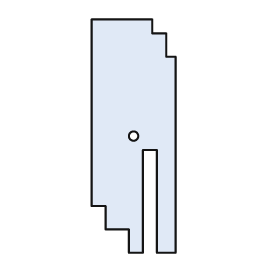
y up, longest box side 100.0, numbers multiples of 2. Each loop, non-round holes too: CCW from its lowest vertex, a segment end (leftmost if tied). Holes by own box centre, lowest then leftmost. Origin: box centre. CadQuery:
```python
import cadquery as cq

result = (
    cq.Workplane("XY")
    .moveTo(-2.0, -50.0)
    .lineTo(4.0, -50.0)
    .lineTo(4.0, -6.0)
    .lineTo(10.0, -6.0)
    .lineTo(10.0, -50.0)
    .lineTo(18.0, -50.0)
    .lineTo(18.0, 34.0)
    .lineTo(14.0, 34.0)
    .lineTo(14.0, 44.0)
    .lineTo(8.0, 44.0)
    .lineTo(8.0, 50.0)
    .lineTo(-18.0, 50.0)
    .lineTo(-18.0, -30.0)
    .lineTo(-12.0, -30.0)
    .lineTo(-12.0, -40.0)
    .lineTo(-2.0, -40.0)
    .close()
    .moveTo(0.0, 0.0)
    .circle(2.0)
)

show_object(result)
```